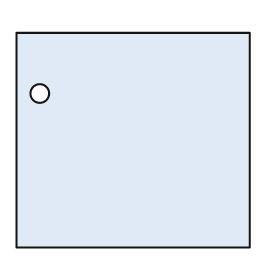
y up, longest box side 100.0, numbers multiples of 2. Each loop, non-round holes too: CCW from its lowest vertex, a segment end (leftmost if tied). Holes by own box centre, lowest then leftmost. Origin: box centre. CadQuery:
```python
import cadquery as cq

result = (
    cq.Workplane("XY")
    .moveTo(-50.0, -46.0)
    .lineTo(50.0, -46.0)
    .lineTo(50.0, 46.0)
    .lineTo(-50.0, 46.0)
    .close()
    .moveTo(-40.0, 20.0)
    .circle(4.0)
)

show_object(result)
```